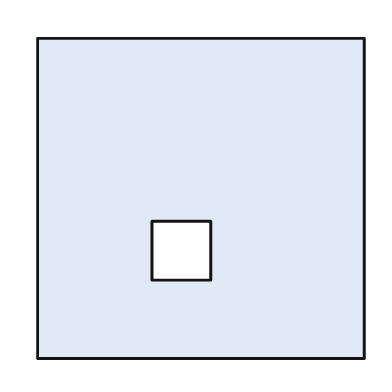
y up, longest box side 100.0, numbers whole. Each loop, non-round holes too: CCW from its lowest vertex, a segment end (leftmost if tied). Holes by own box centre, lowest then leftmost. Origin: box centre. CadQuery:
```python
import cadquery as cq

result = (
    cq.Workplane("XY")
    .moveTo(-50.0, -49.0)
    .lineTo(50.0, -49.0)
    .lineTo(50.0, 49.0)
    .lineTo(-50.0, 49.0)
    .close()
    .moveTo(-15.0, -25.0)
    .lineTo(3.0, -25.0)
    .lineTo(3.0, -7.0)
    .lineTo(-15.0, -7.0)
    .close()
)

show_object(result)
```